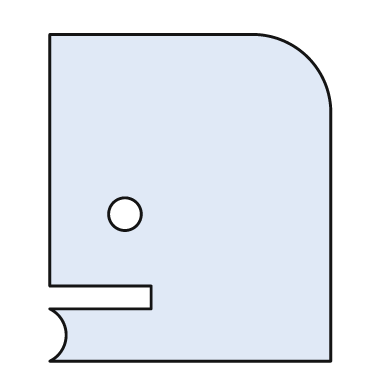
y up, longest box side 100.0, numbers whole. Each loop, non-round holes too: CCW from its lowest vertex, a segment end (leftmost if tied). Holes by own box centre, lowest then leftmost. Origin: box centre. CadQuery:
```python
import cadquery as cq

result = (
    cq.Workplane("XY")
    .moveTo(-43.0, -50.0)
    .lineTo(43.0, -50.0)
    .lineTo(43.0, 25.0)
    .threePointArc((36.0, 43.0), (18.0, 50.0))
    .lineTo(-43.0, 50.0)
    .lineTo(-43.0, -27.0)
    .lineTo(-12.0, -27.0)
    .lineTo(-12.0, -34.0)
    .lineTo(-43.0, -34.0)
    .threePointArc((-38.0, -42.0), (-43.0, -50.0))
    .close()
    .moveTo(-20.0, -5.0)
    .circle(5.0)
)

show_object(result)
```